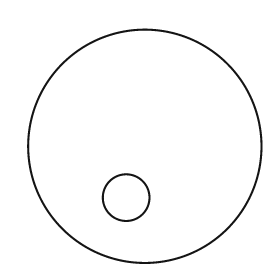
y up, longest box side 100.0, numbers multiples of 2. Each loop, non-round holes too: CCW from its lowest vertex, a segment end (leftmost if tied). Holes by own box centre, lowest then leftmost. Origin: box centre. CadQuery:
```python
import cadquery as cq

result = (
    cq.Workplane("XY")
    .moveTo(0.0, 0.0)
    .circle(50.0)
    .moveTo(-8.0, -22.0)
    .circle(10.0)
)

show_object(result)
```